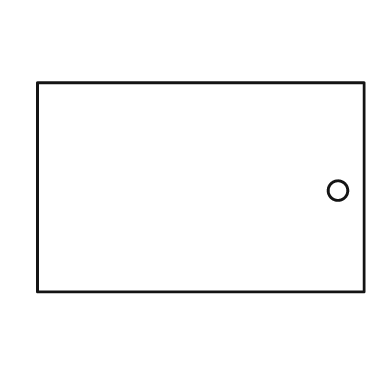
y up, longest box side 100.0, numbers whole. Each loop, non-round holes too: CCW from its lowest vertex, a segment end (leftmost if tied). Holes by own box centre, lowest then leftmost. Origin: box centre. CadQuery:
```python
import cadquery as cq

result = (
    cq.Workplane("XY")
    .moveTo(-50.0, -32.0)
    .lineTo(50.0, -32.0)
    .lineTo(50.0, 32.0)
    .lineTo(-50.0, 32.0)
    .close()
    .moveTo(42.0, -1.0)
    .circle(3.0)
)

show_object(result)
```